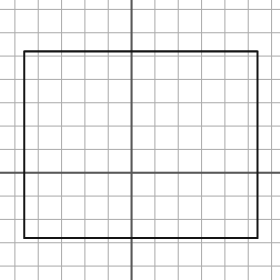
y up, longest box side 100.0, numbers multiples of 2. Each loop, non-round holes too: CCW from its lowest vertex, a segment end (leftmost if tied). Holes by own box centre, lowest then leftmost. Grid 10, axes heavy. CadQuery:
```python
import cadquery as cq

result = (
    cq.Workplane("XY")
    .moveTo(-46.0, -28.0)
    .lineTo(54.0, -28.0)
    .lineTo(54.0, 52.0)
    .lineTo(-46.0, 52.0)
    .close()
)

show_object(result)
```